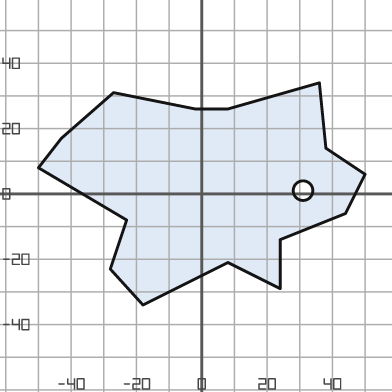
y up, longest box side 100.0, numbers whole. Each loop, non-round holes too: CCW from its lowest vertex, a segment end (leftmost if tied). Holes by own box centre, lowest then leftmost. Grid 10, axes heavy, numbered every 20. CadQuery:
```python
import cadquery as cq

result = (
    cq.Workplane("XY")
    .moveTo(-18.0, -34.0)
    .lineTo(8.0, -21.0)
    .lineTo(24.0, -29.0)
    .lineTo(24.0, -14.0)
    .lineTo(44.0, -6.0)
    .lineTo(50.0, 6.0)
    .lineTo(38.0, 14.0)
    .lineTo(36.0, 34.0)
    .lineTo(8.0, 26.0)
    .lineTo(-2.0, 26.0)
    .lineTo(-27.0, 31.0)
    .lineTo(-43.0, 17.0)
    .lineTo(-50.0, 8.0)
    .lineTo(-23.0, -8.0)
    .lineTo(-28.0, -23.0)
    .close()
    .moveTo(31.0, 1.0)
    .circle(3.0)
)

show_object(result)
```